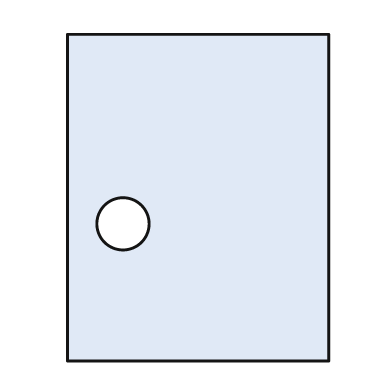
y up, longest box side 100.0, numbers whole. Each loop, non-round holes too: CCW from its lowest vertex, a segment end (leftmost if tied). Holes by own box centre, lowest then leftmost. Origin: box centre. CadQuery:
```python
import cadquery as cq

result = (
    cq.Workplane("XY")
    .moveTo(-40.0, -50.0)
    .lineTo(40.0, -50.0)
    .lineTo(40.0, 50.0)
    .lineTo(-40.0, 50.0)
    .close()
    .moveTo(-23.0, -8.0)
    .circle(8.0)
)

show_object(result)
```